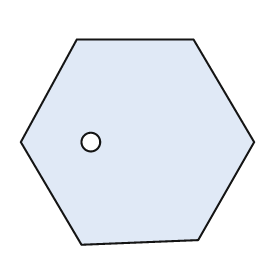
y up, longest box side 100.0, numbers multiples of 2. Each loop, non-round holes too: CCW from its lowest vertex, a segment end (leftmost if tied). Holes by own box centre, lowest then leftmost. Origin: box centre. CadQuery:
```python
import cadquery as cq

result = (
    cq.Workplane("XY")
    .moveTo(-24.0, -44.0)
    .lineTo(26.0, -42.0)
    .lineTo(50.0, 0.0)
    .lineTo(24.0, 44.0)
    .lineTo(-26.0, 44.0)
    .lineTo(-50.0, 0.0)
    .close()
    .moveTo(-20.0, 0.0)
    .circle(4.0)
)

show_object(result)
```